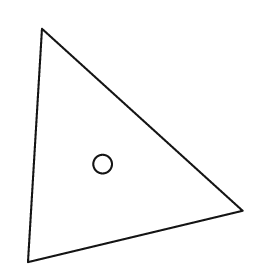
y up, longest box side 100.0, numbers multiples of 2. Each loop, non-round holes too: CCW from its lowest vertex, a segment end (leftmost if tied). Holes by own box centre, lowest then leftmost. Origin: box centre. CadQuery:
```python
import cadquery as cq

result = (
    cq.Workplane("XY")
    .moveTo(-46.0, -50.0)
    .lineTo(46.0, -28.0)
    .lineTo(-40.0, 50.0)
    .close()
    .moveTo(-14.0, -8.0)
    .circle(4.0)
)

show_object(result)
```